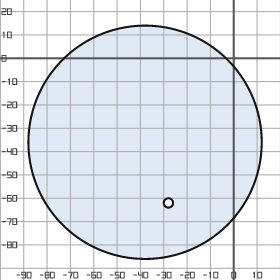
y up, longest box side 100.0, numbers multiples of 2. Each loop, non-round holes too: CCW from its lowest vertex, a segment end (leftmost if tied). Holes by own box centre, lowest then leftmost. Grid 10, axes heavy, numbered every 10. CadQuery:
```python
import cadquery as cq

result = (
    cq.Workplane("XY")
    .moveTo(-38.0, -36.0)
    .circle(50.0)
    .moveTo(-28.0, -62.0)
    .circle(2.0)
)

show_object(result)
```